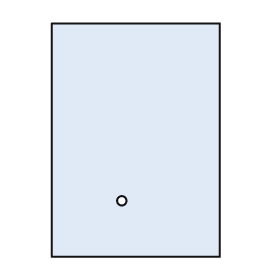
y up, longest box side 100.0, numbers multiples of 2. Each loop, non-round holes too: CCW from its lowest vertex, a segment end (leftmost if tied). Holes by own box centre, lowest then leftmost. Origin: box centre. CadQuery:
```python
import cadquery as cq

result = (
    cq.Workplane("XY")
    .moveTo(-36.0, -50.0)
    .lineTo(36.0, -50.0)
    .lineTo(36.0, 50.0)
    .lineTo(-36.0, 50.0)
    .close()
    .moveTo(-6.0, -26.0)
    .circle(2.0)
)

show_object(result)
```